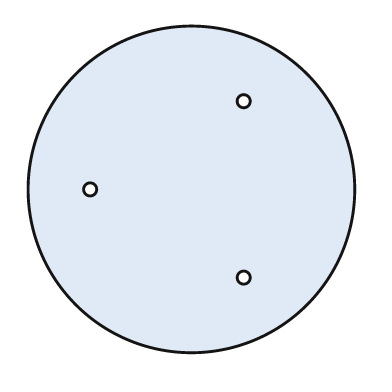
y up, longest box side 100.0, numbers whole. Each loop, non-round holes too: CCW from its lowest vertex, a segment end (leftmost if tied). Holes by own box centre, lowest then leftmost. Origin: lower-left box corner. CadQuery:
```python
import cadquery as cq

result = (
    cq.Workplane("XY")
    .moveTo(50.0, 50.0)
    .circle(50.0)
    .moveTo(66.0, 23.0)
    .circle(2.0)
    .moveTo(19.0, 50.0)
    .circle(2.0)
    .moveTo(66.0, 77.0)
    .circle(2.0)
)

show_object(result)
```